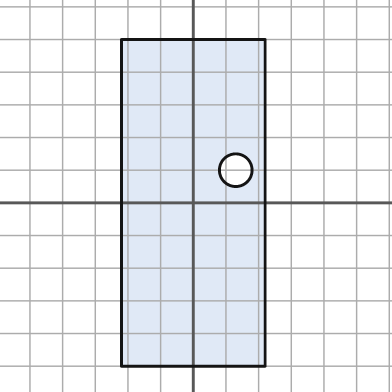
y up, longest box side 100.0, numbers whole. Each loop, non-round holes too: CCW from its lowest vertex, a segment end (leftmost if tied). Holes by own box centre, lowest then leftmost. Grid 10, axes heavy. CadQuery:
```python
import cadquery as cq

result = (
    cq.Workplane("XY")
    .moveTo(-22.0, -50.0)
    .lineTo(22.0, -50.0)
    .lineTo(22.0, 50.0)
    .lineTo(-22.0, 50.0)
    .close()
    .moveTo(13.0, 10.0)
    .circle(5.0)
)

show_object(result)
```